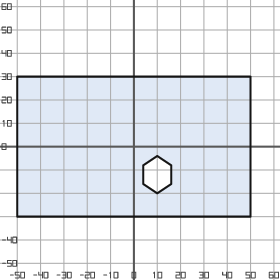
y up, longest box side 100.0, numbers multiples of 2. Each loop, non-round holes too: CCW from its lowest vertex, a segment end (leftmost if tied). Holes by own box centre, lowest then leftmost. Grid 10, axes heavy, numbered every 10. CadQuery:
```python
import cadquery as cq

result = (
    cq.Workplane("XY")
    .moveTo(-50.0, -30.0)
    .lineTo(50.0, -30.0)
    .lineTo(50.0, 30.0)
    .lineTo(-50.0, 30.0)
    .close()
    .moveTo(10.0, -20.0)
    .lineTo(16.0, -16.0)
    .lineTo(16.0, -8.0)
    .lineTo(10.0, -4.0)
    .lineTo(4.0, -8.0)
    .lineTo(4.0, -16.0)
    .close()
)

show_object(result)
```